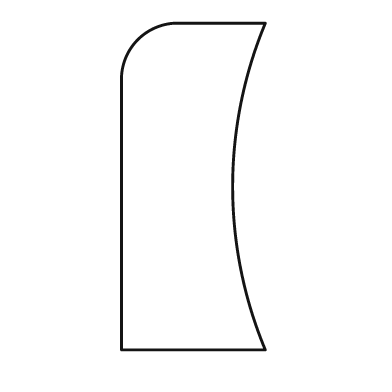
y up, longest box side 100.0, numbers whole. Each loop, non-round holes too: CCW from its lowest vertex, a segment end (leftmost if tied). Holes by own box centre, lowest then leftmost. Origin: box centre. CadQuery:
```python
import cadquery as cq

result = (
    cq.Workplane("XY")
    .moveTo(-22.0, -50.0)
    .lineTo(22.0, -50.0)
    .threePointArc((12.0, 0.0), (22.0, 50.0))
    .lineTo(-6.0, 50.0)
    .threePointArc((-17.0, 45.0), (-22.0, 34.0))
    .close()
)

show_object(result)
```